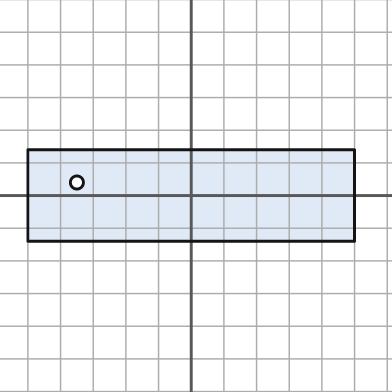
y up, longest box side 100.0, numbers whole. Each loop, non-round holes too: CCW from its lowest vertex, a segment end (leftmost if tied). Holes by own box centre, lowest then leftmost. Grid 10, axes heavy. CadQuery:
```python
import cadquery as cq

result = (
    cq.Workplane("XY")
    .moveTo(-50.0, -14.0)
    .lineTo(50.0, -14.0)
    .lineTo(50.0, 14.0)
    .lineTo(-50.0, 14.0)
    .close()
    .moveTo(-35.0, 4.0)
    .circle(2.0)
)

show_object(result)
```